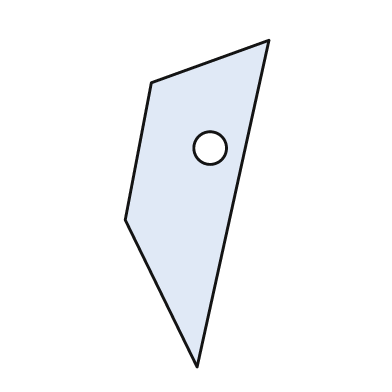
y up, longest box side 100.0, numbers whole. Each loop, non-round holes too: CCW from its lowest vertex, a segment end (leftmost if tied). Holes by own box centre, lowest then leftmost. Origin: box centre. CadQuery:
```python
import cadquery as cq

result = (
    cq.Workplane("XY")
    .moveTo(0.0, -50.0)
    .lineTo(22.0, 50.0)
    .lineTo(-14.0, 37.0)
    .lineTo(-22.0, -5.0)
    .close()
    .moveTo(4.0, 17.0)
    .circle(5.0)
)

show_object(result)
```